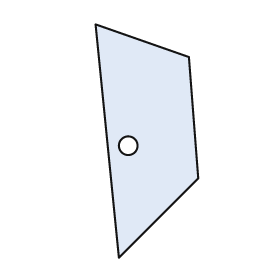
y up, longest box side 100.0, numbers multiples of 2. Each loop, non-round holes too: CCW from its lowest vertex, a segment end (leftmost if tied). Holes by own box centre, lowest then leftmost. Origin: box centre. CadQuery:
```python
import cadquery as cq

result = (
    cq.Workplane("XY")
    .moveTo(-12.0, -50.0)
    .lineTo(22.0, -16.0)
    .lineTo(18.0, 36.0)
    .lineTo(-22.0, 50.0)
    .close()
    .moveTo(-8.0, -2.0)
    .circle(4.0)
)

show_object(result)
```